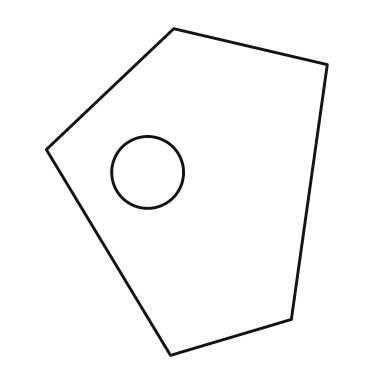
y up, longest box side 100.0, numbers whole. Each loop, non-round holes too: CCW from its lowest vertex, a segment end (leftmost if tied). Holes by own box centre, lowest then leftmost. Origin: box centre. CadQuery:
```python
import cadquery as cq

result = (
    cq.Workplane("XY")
    .moveTo(-5.0, -50.0)
    .lineTo(32.0, -39.0)
    .lineTo(43.0, 39.0)
    .lineTo(-4.0, 50.0)
    .lineTo(-43.0, 13.0)
    .close()
    .moveTo(-12.0, 6.0)
    .circle(11.0)
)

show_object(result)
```